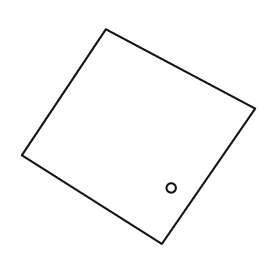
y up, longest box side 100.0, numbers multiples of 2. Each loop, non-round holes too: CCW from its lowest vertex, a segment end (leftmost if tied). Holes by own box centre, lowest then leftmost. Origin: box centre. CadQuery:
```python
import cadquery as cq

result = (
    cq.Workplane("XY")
    .moveTo(10.0, -46.0)
    .lineTo(50.0, 12.0)
    .lineTo(-14.0, 46.0)
    .lineTo(-50.0, -8.0)
    .close()
    .moveTo(14.0, -22.0)
    .circle(2.0)
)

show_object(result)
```